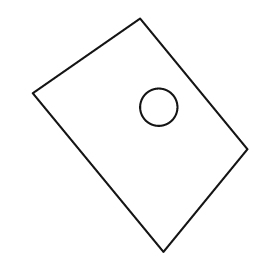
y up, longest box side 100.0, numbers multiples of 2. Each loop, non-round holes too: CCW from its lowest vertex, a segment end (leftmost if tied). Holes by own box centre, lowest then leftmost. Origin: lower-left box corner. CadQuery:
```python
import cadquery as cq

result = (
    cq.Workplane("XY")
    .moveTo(56.0, 0.0)
    .lineTo(92.0, 44.0)
    .lineTo(46.0, 100.0)
    .lineTo(0.0, 68.0)
    .close()
    .moveTo(54.0, 62.0)
    .circle(8.0)
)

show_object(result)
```